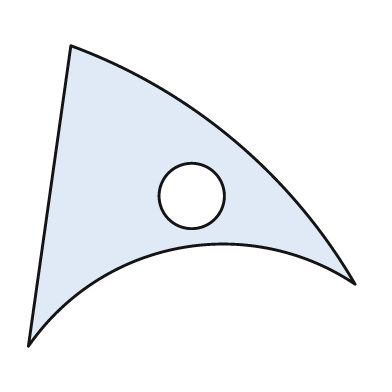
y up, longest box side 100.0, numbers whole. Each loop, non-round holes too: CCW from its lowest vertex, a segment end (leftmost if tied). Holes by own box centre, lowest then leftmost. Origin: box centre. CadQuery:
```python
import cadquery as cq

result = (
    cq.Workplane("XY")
    .moveTo(-50.0, -46.0)
    .threePointArc((-4.0, -16.0), (50.0, -27.0))
    .threePointArc((13.0, 17.0), (-37.0, 46.0))
    .close()
    .moveTo(0.0, 0.0)
    .circle(10.0)
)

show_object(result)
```